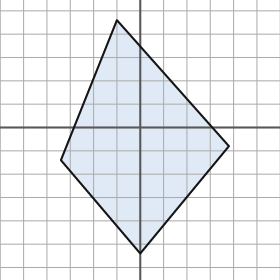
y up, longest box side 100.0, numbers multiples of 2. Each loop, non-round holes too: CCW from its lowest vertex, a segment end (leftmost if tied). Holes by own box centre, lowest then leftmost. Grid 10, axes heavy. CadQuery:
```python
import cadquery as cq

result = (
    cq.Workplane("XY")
    .moveTo(0.0, -54.0)
    .lineTo(38.0, -8.0)
    .lineTo(-10.0, 46.0)
    .lineTo(-34.0, -14.0)
    .close()
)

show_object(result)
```